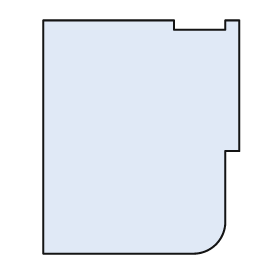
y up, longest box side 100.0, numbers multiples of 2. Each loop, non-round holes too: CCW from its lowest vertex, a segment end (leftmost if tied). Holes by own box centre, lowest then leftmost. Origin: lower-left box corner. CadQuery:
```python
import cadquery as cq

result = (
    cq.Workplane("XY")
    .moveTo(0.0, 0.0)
    .lineTo(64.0, 0.0)
    .threePointArc((74.0, 4.0), (78.0, 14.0))
    .lineTo(78.0, 44.0)
    .lineTo(84.0, 44.0)
    .lineTo(84.0, 100.0)
    .lineTo(78.0, 100.0)
    .lineTo(78.0, 96.0)
    .lineTo(56.0, 96.0)
    .lineTo(56.0, 100.0)
    .lineTo(0.0, 100.0)
    .close()
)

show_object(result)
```